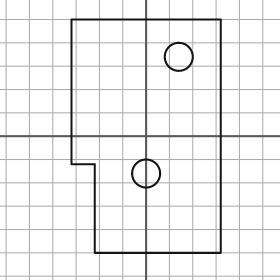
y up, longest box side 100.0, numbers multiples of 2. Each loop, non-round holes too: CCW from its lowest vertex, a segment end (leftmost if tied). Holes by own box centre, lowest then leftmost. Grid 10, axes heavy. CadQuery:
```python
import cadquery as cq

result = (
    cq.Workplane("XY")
    .moveTo(-22.0, -50.0)
    .lineTo(32.0, -50.0)
    .lineTo(32.0, 50.0)
    .lineTo(-32.0, 50.0)
    .lineTo(-32.0, -12.0)
    .lineTo(-22.0, -12.0)
    .close()
    .moveTo(0.0, -16.0)
    .circle(6.0)
    .moveTo(14.0, 34.0)
    .circle(6.0)
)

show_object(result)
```